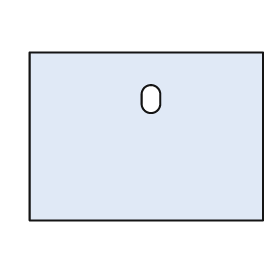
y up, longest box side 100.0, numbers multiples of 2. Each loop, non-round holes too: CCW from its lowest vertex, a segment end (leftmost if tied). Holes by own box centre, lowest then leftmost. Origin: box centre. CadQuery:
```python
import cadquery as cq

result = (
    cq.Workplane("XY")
    .moveTo(-50.0, -36.0)
    .lineTo(50.0, -36.0)
    .lineTo(50.0, 36.0)
    .lineTo(-50.0, 36.0)
    .close()
    .moveTo(-2.0, 14.0)
    .threePointArc((2.0, 10.0), (6.0, 14.0))
    .lineTo(6.0, 18.0)
    .threePointArc((2.0, 22.0), (-2.0, 18.0))
    .close()
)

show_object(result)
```